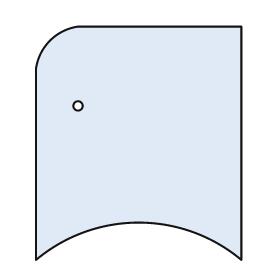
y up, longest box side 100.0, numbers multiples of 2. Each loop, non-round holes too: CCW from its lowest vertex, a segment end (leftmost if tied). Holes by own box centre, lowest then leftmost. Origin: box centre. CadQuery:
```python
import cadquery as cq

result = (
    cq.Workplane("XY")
    .moveTo(-44.0, -50.0)
    .threePointArc((0.0, -34.0), (44.0, -50.0))
    .lineTo(44.0, 50.0)
    .lineTo(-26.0, 50.0)
    .threePointArc((-38.0, 44.0), (-44.0, 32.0))
    .close()
    .moveTo(-26.0, 16.0)
    .circle(2.0)
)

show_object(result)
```